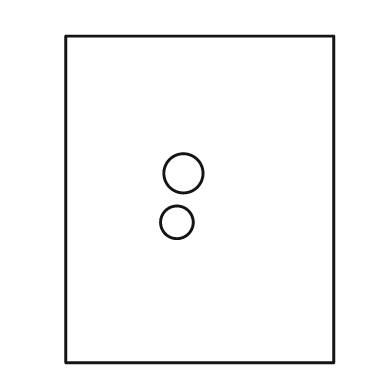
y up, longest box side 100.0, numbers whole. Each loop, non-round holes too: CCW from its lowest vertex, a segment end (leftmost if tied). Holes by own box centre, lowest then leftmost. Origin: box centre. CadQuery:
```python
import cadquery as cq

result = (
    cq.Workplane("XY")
    .moveTo(-41.0, -50.0)
    .lineTo(41.0, -50.0)
    .lineTo(41.0, 50.0)
    .lineTo(-41.0, 50.0)
    .close()
    .moveTo(-7.0, -7.0)
    .circle(5.0)
    .moveTo(-5.0, 8.0)
    .circle(6.0)
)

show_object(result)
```